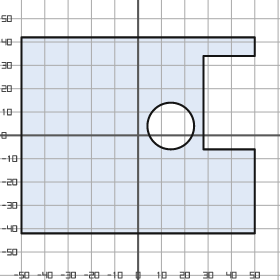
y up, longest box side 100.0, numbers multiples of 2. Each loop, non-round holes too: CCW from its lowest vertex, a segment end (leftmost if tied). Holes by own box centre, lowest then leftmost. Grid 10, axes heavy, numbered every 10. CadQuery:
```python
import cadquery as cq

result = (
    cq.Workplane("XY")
    .moveTo(-50.0, -42.0)
    .lineTo(50.0, -42.0)
    .lineTo(50.0, -6.0)
    .lineTo(28.0, -6.0)
    .lineTo(28.0, 34.0)
    .lineTo(50.0, 34.0)
    .lineTo(50.0, 42.0)
    .lineTo(-50.0, 42.0)
    .close()
    .moveTo(14.0, 4.0)
    .circle(10.0)
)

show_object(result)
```